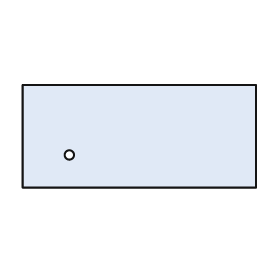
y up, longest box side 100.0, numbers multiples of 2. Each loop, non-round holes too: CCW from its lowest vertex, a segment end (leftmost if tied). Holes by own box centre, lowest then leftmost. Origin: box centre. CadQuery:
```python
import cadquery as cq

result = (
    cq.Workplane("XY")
    .moveTo(-50.0, -22.0)
    .lineTo(50.0, -22.0)
    .lineTo(50.0, 22.0)
    .lineTo(-50.0, 22.0)
    .close()
    .moveTo(-30.0, -8.0)
    .circle(2.0)
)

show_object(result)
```